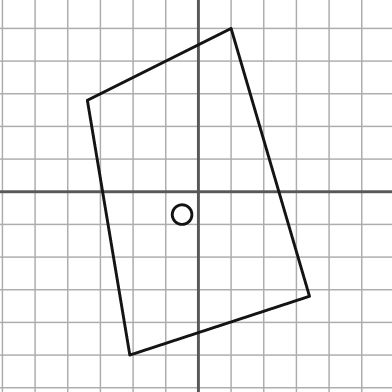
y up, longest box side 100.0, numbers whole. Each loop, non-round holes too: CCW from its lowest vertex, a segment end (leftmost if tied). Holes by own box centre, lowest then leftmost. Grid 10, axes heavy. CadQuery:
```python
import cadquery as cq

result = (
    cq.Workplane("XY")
    .moveTo(-21.0, -50.0)
    .lineTo(34.0, -32.0)
    .lineTo(10.0, 50.0)
    .lineTo(-34.0, 28.0)
    .close()
    .moveTo(-5.0, -7.0)
    .circle(3.0)
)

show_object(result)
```